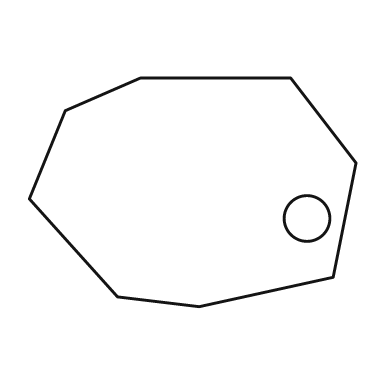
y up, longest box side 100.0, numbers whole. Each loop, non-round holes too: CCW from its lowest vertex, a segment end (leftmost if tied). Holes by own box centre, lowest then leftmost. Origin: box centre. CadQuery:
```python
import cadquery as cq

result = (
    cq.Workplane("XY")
    .moveTo(2.0, -35.0)
    .lineTo(43.0, -26.0)
    .lineTo(50.0, 9.0)
    .lineTo(30.0, 35.0)
    .lineTo(-16.0, 35.0)
    .lineTo(-39.0, 25.0)
    .lineTo(-50.0, -2.0)
    .lineTo(-23.0, -32.0)
    .close()
    .moveTo(35.0, -8.0)
    .circle(7.0)
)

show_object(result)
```